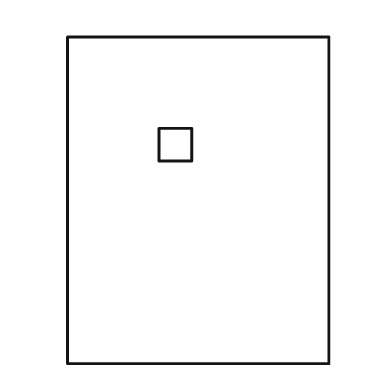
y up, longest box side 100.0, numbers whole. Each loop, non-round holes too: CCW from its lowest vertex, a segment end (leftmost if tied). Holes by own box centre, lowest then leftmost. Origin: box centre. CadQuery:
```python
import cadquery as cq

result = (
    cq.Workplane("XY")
    .moveTo(-40.0, -50.0)
    .lineTo(40.0, -50.0)
    .lineTo(40.0, 50.0)
    .lineTo(-40.0, 50.0)
    .close()
    .moveTo(-12.0, 12.0)
    .lineTo(-2.0, 12.0)
    .lineTo(-2.0, 22.0)
    .lineTo(-12.0, 22.0)
    .close()
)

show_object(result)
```